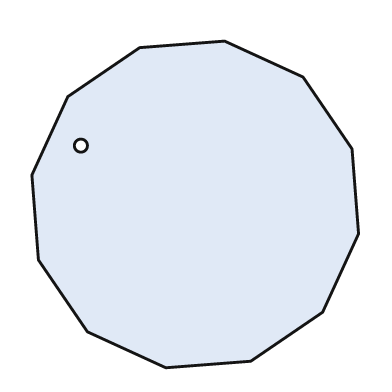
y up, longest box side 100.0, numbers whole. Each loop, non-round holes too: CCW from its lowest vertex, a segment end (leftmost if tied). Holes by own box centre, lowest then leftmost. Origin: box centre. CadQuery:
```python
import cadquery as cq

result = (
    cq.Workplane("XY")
    .moveTo(-9.0, -50.0)
    .lineTo(17.0, -48.0)
    .lineTo(39.0, -33.0)
    .lineTo(50.0, -9.0)
    .lineTo(48.0, 17.0)
    .lineTo(33.0, 39.0)
    .lineTo(9.0, 50.0)
    .lineTo(-17.0, 48.0)
    .lineTo(-39.0, 33.0)
    .lineTo(-50.0, 9.0)
    .lineTo(-48.0, -17.0)
    .lineTo(-33.0, -39.0)
    .close()
    .moveTo(-35.0, 18.0)
    .circle(2.0)
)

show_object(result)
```